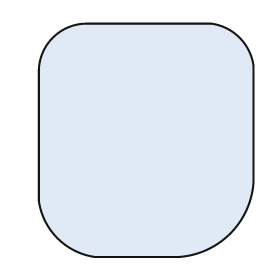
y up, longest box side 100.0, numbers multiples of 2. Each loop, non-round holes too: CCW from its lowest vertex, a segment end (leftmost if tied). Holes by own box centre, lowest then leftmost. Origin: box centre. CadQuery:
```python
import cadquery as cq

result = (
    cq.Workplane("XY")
    .moveTo(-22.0, -50.0)
    .lineTo(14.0, -50.0)
    .threePointArc((36.0, -40.0), (46.0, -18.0))
    .lineTo(46.0, 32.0)
    .threePointArc((40.0, 44.0), (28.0, 50.0))
    .lineTo(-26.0, 50.0)
    .threePointArc((-40.0, 44.0), (-46.0, 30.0))
    .lineTo(-46.0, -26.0)
    .threePointArc((-38.0, -42.0), (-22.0, -50.0))
    .close()
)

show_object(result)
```